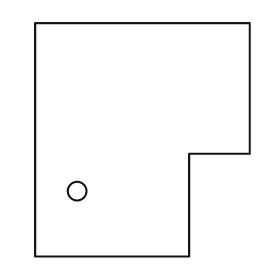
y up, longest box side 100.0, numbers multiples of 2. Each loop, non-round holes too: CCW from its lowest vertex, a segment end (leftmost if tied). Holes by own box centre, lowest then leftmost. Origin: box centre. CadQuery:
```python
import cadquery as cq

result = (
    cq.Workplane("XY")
    .moveTo(-46.0, -50.0)
    .lineTo(20.0, -50.0)
    .lineTo(20.0, -6.0)
    .lineTo(46.0, -6.0)
    .lineTo(46.0, 50.0)
    .lineTo(-46.0, 50.0)
    .close()
    .moveTo(-28.0, -22.0)
    .circle(4.0)
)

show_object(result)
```